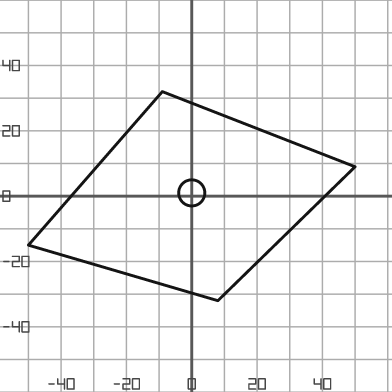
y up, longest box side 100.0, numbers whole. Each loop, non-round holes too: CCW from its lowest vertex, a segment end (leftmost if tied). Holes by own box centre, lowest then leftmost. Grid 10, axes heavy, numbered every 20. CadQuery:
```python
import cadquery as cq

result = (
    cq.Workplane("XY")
    .moveTo(8.0, -32.0)
    .lineTo(50.0, 9.0)
    .lineTo(-9.0, 32.0)
    .lineTo(-50.0, -15.0)
    .close()
    .moveTo(0.0, 1.0)
    .circle(4.0)
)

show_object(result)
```